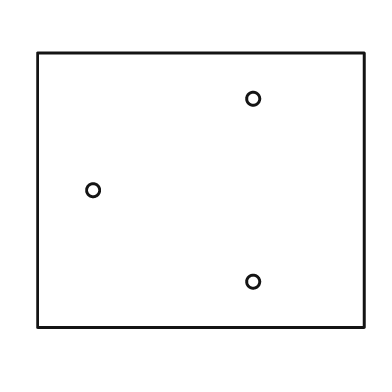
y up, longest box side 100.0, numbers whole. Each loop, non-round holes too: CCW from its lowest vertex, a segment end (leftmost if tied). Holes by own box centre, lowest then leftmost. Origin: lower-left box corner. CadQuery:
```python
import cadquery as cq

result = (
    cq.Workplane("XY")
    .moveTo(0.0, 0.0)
    .lineTo(100.0, 0.0)
    .lineTo(100.0, 84.0)
    .lineTo(0.0, 84.0)
    .close()
    .moveTo(66.0, 14.0)
    .circle(2.0)
    .moveTo(17.0, 42.0)
    .circle(2.0)
    .moveTo(66.0, 70.0)
    .circle(2.0)
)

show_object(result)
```